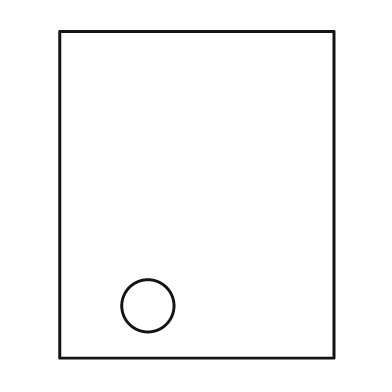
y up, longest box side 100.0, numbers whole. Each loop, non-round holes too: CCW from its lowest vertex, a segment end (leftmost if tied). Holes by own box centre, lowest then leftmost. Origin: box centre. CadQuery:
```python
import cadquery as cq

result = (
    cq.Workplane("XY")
    .moveTo(-42.0, -50.0)
    .lineTo(42.0, -50.0)
    .lineTo(42.0, 50.0)
    .lineTo(-42.0, 50.0)
    .close()
    .moveTo(-15.0, -34.0)
    .circle(8.0)
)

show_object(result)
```